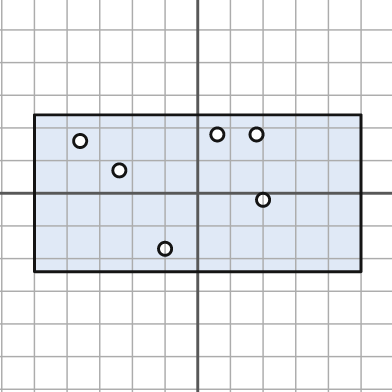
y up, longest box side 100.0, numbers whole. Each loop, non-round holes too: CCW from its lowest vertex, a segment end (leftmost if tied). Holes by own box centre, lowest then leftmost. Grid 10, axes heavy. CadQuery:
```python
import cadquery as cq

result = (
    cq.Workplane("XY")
    .moveTo(-50.0, -24.0)
    .lineTo(50.0, -24.0)
    .lineTo(50.0, 24.0)
    .lineTo(-50.0, 24.0)
    .close()
    .moveTo(-10.0, -17.0)
    .circle(2.0)
    .moveTo(20.0, -2.0)
    .circle(2.0)
    .moveTo(-24.0, 7.0)
    .circle(2.0)
    .moveTo(-36.0, 16.0)
    .circle(2.0)
    .moveTo(6.0, 18.0)
    .circle(2.0)
    .moveTo(18.0, 18.0)
    .circle(2.0)
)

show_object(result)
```